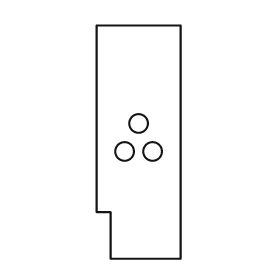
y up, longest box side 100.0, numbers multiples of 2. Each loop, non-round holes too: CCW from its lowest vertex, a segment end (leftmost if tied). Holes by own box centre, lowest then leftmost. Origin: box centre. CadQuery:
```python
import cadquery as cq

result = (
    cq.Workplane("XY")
    .moveTo(-12.0, -50.0)
    .lineTo(18.0, -50.0)
    .lineTo(18.0, 50.0)
    .lineTo(-18.0, 50.0)
    .lineTo(-18.0, -30.0)
    .lineTo(-12.0, -30.0)
    .close()
    .moveTo(-6.0, -4.0)
    .circle(4.0)
    .moveTo(6.0, -4.0)
    .circle(4.0)
    .moveTo(0.0, 8.0)
    .circle(4.0)
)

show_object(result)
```